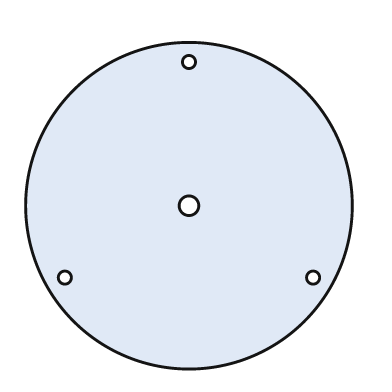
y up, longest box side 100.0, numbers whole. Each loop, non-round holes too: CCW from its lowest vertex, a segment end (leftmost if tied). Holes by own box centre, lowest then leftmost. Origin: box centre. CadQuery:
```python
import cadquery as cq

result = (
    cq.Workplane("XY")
    .moveTo(0.0, 0.0)
    .circle(50.0)
    .moveTo(-38.0, -22.0)
    .circle(2.0)
    .moveTo(38.0, -22.0)
    .circle(2.0)
    .moveTo(0.0, 0.0)
    .circle(3.0)
    .moveTo(0.0, 44.0)
    .circle(2.0)
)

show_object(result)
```